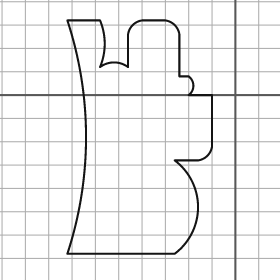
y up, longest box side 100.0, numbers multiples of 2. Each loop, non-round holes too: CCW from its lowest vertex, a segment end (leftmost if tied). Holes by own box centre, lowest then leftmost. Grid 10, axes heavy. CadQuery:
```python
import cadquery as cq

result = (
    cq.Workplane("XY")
    .moveTo(-72.0, -68.0)
    .lineTo(-26.0, -68.0)
    .threePointArc((-16.0, -48.0), (-26.0, -28.0))
    .lineTo(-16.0, -28.0)
    .threePointArc((-12.0, -26.0), (-10.0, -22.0))
    .lineTo(-10.0, 0.0)
    .lineTo(-20.0, 0.0)
    .threePointArc((-18.0, 4.0), (-20.0, 8.0))
    .lineTo(-24.0, 8.0)
    .lineTo(-24.0, 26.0)
    .threePointArc((-26.0, 30.0), (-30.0, 32.0))
    .lineTo(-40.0, 32.0)
    .threePointArc((-44.0, 30.0), (-46.0, 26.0))
    .lineTo(-46.0, 12.0)
    .threePointArc((-52.0, 14.0), (-58.0, 12.0))
    .threePointArc((-56.0, 22.0), (-58.0, 32.0))
    .lineTo(-72.0, 32.0)
    .threePointArc((-64.0, -18.0), (-72.0, -68.0))
    .close()
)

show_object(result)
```